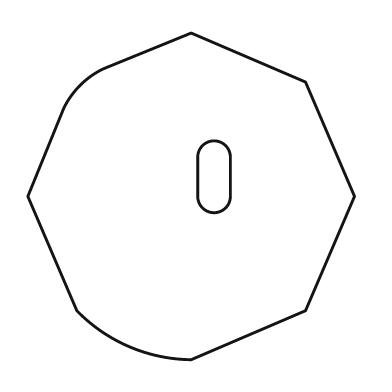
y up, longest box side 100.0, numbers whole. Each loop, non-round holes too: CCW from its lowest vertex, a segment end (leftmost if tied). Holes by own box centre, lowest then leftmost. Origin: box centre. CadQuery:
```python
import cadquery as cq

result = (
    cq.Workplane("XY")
    .moveTo(0.0, -50.0)
    .lineTo(35.0, -35.0)
    .lineTo(50.0, 0.0)
    .lineTo(35.0, 35.0)
    .lineTo(0.0, 50.0)
    .lineTo(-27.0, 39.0)
    .threePointArc((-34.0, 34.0), (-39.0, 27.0))
    .lineTo(-50.0, 0.0)
    .lineTo(-35.0, -35.0)
    .threePointArc((-19.0, -46.0), (0.0, -50.0))
    .close()
    .moveTo(2.0, 0.0)
    .threePointArc((7.0, -5.0), (12.0, 0.0))
    .lineTo(12.0, 12.0)
    .threePointArc((7.0, 17.0), (2.0, 12.0))
    .close()
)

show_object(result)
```